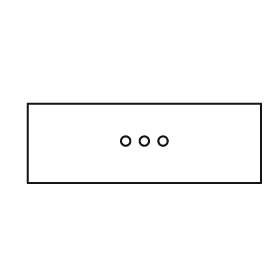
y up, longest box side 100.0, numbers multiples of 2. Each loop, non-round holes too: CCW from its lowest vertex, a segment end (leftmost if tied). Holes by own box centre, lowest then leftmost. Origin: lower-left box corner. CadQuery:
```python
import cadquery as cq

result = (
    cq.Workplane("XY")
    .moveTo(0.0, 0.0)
    .lineTo(100.0, 0.0)
    .lineTo(100.0, 34.0)
    .lineTo(0.0, 34.0)
    .close()
    .moveTo(42.0, 18.0)
    .circle(2.0)
    .moveTo(50.0, 18.0)
    .circle(2.0)
    .moveTo(58.0, 18.0)
    .circle(2.0)
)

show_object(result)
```